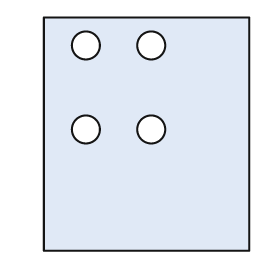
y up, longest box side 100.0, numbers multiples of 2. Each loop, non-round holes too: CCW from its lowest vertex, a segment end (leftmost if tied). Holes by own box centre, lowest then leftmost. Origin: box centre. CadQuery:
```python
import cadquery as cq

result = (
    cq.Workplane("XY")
    .moveTo(-44.0, -50.0)
    .lineTo(44.0, -50.0)
    .lineTo(44.0, 50.0)
    .lineTo(-44.0, 50.0)
    .close()
    .moveTo(-26.0, 2.0)
    .circle(6.0)
    .moveTo(2.0, 2.0)
    .circle(6.0)
    .moveTo(-26.0, 38.0)
    .circle(6.0)
    .moveTo(2.0, 38.0)
    .circle(6.0)
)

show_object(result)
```